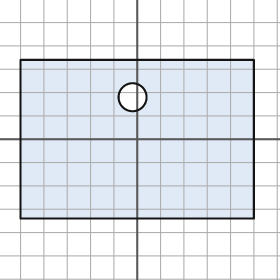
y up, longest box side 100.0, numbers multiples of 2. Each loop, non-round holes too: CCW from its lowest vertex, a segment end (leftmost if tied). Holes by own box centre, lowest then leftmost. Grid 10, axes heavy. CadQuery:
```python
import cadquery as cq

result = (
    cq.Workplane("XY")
    .moveTo(-50.0, -34.0)
    .lineTo(50.0, -34.0)
    .lineTo(50.0, 34.0)
    .lineTo(-50.0, 34.0)
    .close()
    .moveTo(-2.0, 18.0)
    .circle(6.0)
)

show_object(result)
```